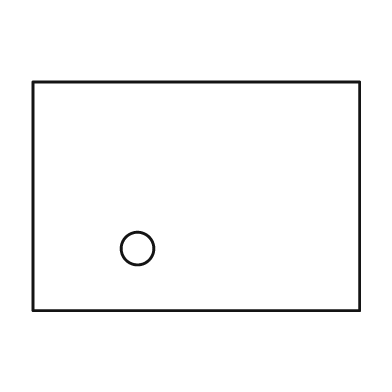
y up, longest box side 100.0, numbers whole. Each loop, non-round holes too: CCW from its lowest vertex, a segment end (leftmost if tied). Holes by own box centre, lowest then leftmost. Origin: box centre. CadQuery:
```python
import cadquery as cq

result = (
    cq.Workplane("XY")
    .moveTo(-50.0, -35.0)
    .lineTo(50.0, -35.0)
    .lineTo(50.0, 35.0)
    .lineTo(-50.0, 35.0)
    .close()
    .moveTo(-18.0, -16.0)
    .circle(5.0)
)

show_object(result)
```